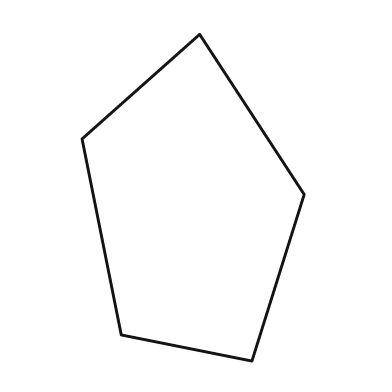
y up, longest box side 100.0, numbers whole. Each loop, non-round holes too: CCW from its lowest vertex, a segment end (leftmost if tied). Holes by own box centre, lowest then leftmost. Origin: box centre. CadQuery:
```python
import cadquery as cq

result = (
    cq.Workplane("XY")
    .moveTo(18.0, -50.0)
    .lineTo(34.0, 1.0)
    .lineTo(2.0, 50.0)
    .lineTo(-34.0, 18.0)
    .lineTo(-22.0, -42.0)
    .close()
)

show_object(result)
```